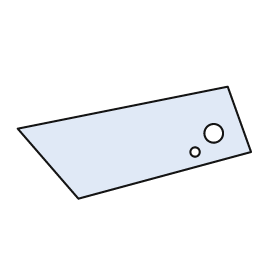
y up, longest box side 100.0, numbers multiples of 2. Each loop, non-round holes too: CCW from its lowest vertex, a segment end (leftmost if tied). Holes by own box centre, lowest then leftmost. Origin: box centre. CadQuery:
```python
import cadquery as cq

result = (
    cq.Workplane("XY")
    .moveTo(-24.0, -24.0)
    .lineTo(50.0, -4.0)
    .lineTo(40.0, 24.0)
    .lineTo(-50.0, 6.0)
    .close()
    .moveTo(26.0, -4.0)
    .circle(2.0)
    .moveTo(34.0, 4.0)
    .circle(4.0)
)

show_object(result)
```